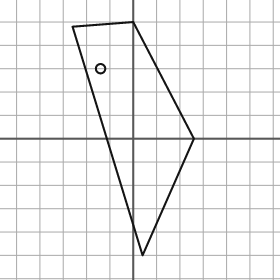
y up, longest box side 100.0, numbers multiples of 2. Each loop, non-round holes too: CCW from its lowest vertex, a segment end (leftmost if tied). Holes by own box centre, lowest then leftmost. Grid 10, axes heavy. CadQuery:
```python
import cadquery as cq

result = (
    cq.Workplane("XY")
    .moveTo(4.0, -50.0)
    .lineTo(26.0, 0.0)
    .lineTo(0.0, 50.0)
    .lineTo(-26.0, 48.0)
    .close()
    .moveTo(-14.0, 30.0)
    .circle(2.0)
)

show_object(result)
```